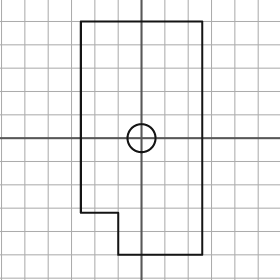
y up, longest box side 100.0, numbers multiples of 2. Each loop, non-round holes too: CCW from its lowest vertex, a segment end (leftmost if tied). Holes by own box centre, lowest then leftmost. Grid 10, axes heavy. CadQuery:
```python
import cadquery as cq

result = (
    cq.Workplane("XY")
    .moveTo(-10.0, -50.0)
    .lineTo(26.0, -50.0)
    .lineTo(26.0, 50.0)
    .lineTo(-26.0, 50.0)
    .lineTo(-26.0, -32.0)
    .lineTo(-10.0, -32.0)
    .close()
    .moveTo(0.0, 0.0)
    .circle(6.0)
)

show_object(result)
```